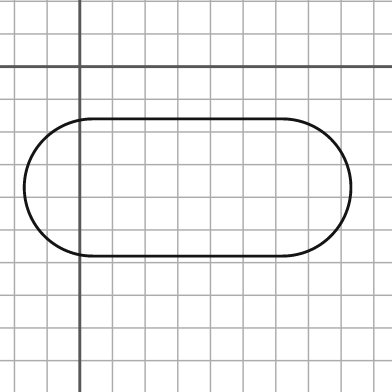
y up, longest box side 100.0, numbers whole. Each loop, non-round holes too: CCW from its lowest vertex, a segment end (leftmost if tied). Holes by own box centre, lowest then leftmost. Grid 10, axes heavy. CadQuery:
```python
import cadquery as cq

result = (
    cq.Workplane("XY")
    .moveTo(4.0, -58.0)
    .lineTo(62.0, -58.0)
    .threePointArc((83.0, -37.0), (62.0, -16.0))
    .lineTo(4.0, -16.0)
    .threePointArc((-17.0, -37.0), (4.0, -58.0))
    .close()
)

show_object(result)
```